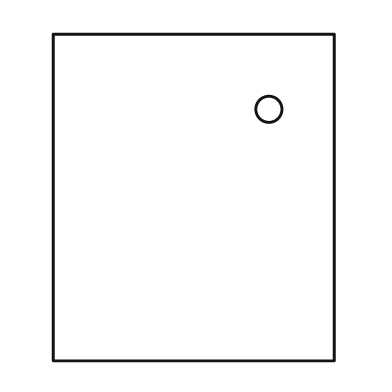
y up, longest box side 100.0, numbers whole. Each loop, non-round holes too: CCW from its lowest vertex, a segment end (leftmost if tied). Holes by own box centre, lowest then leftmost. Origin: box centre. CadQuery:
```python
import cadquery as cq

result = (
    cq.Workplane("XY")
    .moveTo(-43.0, -50.0)
    .lineTo(43.0, -50.0)
    .lineTo(43.0, 50.0)
    .lineTo(-43.0, 50.0)
    .close()
    .moveTo(23.0, 27.0)
    .circle(4.0)
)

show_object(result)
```